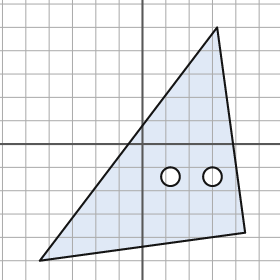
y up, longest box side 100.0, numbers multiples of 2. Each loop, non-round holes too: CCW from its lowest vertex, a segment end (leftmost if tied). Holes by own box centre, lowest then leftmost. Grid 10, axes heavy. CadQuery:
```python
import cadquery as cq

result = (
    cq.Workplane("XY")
    .moveTo(-44.0, -50.0)
    .lineTo(44.0, -38.0)
    .lineTo(32.0, 50.0)
    .close()
    .moveTo(12.0, -14.0)
    .circle(4.0)
    .moveTo(30.0, -14.0)
    .circle(4.0)
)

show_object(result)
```